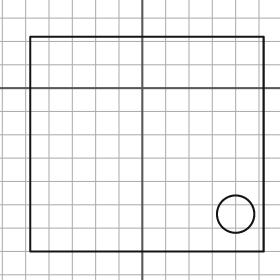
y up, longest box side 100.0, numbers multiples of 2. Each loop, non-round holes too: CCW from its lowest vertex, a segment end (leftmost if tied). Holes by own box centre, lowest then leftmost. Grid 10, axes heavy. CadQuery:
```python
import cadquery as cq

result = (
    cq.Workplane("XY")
    .moveTo(-48.0, -70.0)
    .lineTo(52.0, -70.0)
    .lineTo(52.0, 22.0)
    .lineTo(-48.0, 22.0)
    .close()
    .moveTo(40.0, -54.0)
    .circle(8.0)
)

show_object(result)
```